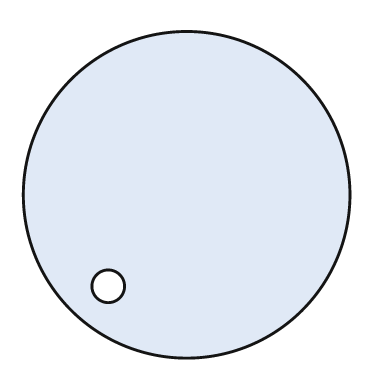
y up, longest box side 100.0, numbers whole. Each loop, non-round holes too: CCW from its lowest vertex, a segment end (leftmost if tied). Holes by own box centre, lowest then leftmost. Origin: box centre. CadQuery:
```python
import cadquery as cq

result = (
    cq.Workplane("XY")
    .moveTo(0.0, 0.0)
    .circle(50.0)
    .moveTo(-24.0, -28.0)
    .circle(5.0)
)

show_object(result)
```